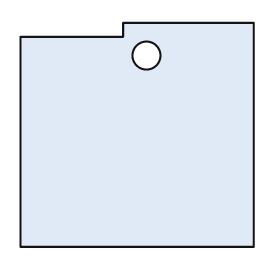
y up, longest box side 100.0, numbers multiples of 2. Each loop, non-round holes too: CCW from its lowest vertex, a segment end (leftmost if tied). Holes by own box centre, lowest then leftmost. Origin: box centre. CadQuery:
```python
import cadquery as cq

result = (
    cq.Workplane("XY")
    .moveTo(-50.0, -48.0)
    .lineTo(50.0, -48.0)
    .lineTo(50.0, 48.0)
    .lineTo(-6.0, 48.0)
    .lineTo(-6.0, 42.0)
    .lineTo(-50.0, 42.0)
    .close()
    .moveTo(4.0, 34.0)
    .circle(6.0)
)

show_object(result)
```